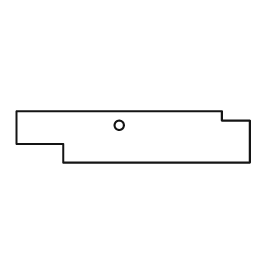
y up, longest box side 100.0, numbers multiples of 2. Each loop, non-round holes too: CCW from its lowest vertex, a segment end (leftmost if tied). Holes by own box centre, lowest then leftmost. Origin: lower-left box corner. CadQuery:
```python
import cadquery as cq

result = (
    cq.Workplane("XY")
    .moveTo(20.0, 0.0)
    .lineTo(100.0, 0.0)
    .lineTo(100.0, 18.0)
    .lineTo(88.0, 18.0)
    .lineTo(88.0, 22.0)
    .lineTo(0.0, 22.0)
    .lineTo(0.0, 8.0)
    .lineTo(20.0, 8.0)
    .close()
    .moveTo(44.0, 16.0)
    .circle(2.0)
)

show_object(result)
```